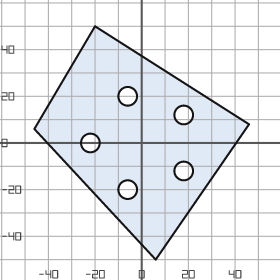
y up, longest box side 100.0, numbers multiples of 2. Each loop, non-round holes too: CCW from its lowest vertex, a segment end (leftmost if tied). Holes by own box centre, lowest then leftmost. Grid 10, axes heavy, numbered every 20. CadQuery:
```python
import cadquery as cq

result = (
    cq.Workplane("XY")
    .moveTo(6.0, -50.0)
    .lineTo(46.0, 8.0)
    .lineTo(-20.0, 50.0)
    .lineTo(-46.0, 6.0)
    .close()
    .moveTo(-6.0, -20.0)
    .circle(4.0)
    .moveTo(18.0, -12.0)
    .circle(4.0)
    .moveTo(-22.0, 0.0)
    .circle(4.0)
    .moveTo(18.0, 12.0)
    .circle(4.0)
    .moveTo(-6.0, 20.0)
    .circle(4.0)
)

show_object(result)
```